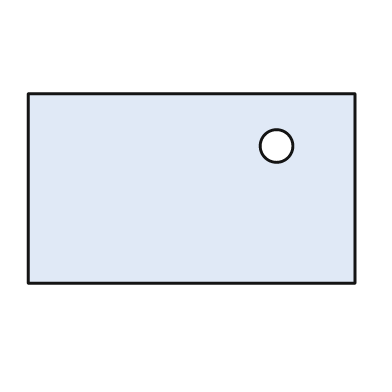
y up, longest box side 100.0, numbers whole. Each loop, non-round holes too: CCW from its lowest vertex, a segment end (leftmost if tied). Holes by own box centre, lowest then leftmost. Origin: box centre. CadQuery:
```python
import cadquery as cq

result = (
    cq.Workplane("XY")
    .moveTo(-50.0, -29.0)
    .lineTo(50.0, -29.0)
    .lineTo(50.0, 29.0)
    .lineTo(-50.0, 29.0)
    .close()
    .moveTo(26.0, 13.0)
    .circle(5.0)
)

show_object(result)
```